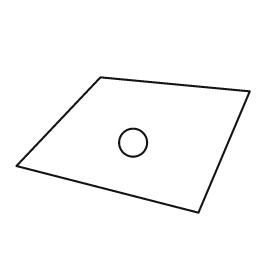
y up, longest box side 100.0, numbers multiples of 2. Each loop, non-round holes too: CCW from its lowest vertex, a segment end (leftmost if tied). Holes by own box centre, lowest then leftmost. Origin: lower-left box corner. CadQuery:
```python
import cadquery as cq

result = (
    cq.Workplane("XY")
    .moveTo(78.0, 0.0)
    .lineTo(100.0, 52.0)
    .lineTo(36.0, 58.0)
    .lineTo(0.0, 20.0)
    .close()
    .moveTo(50.0, 30.0)
    .circle(6.0)
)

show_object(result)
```